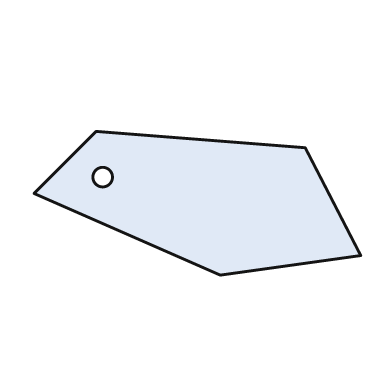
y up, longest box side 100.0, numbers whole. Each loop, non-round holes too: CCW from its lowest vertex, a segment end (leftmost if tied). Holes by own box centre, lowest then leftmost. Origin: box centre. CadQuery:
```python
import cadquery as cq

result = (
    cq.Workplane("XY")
    .moveTo(7.0, -22.0)
    .lineTo(50.0, -16.0)
    .lineTo(33.0, 17.0)
    .lineTo(-31.0, 22.0)
    .lineTo(-50.0, 3.0)
    .close()
    .moveTo(-29.0, 8.0)
    .circle(3.0)
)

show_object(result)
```